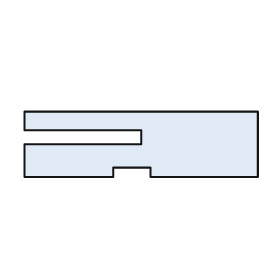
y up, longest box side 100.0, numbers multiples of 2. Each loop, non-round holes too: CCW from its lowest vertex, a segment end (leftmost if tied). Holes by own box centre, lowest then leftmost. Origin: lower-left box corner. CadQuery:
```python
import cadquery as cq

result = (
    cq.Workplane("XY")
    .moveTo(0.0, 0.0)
    .lineTo(38.0, 0.0)
    .lineTo(38.0, 4.0)
    .lineTo(54.0, 4.0)
    .lineTo(54.0, 0.0)
    .lineTo(100.0, 0.0)
    .lineTo(100.0, 28.0)
    .lineTo(0.0, 28.0)
    .lineTo(0.0, 20.0)
    .lineTo(50.0, 20.0)
    .lineTo(50.0, 14.0)
    .lineTo(0.0, 14.0)
    .close()
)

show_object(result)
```